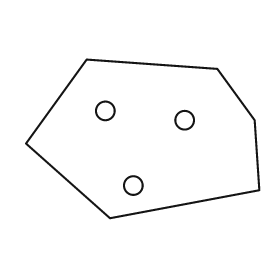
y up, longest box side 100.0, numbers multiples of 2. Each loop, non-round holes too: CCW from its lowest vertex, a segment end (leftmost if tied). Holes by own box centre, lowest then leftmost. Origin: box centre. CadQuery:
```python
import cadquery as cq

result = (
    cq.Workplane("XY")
    .moveTo(-14.0, -34.0)
    .lineTo(50.0, -22.0)
    .lineTo(48.0, 8.0)
    .lineTo(32.0, 30.0)
    .lineTo(-24.0, 34.0)
    .lineTo(-50.0, -2.0)
    .close()
    .moveTo(-4.0, -20.0)
    .circle(4.0)
    .moveTo(18.0, 8.0)
    .circle(4.0)
    .moveTo(-16.0, 12.0)
    .circle(4.0)
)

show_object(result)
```